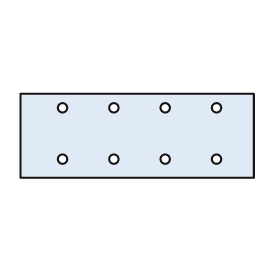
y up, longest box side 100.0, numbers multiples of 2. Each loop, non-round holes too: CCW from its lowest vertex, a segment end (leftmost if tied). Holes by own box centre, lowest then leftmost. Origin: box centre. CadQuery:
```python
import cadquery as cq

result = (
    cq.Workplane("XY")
    .moveTo(-50.0, -18.0)
    .lineTo(50.0, -18.0)
    .lineTo(50.0, 18.0)
    .lineTo(-50.0, 18.0)
    .close()
    .moveTo(-32.0, -10.0)
    .circle(2.0)
    .moveTo(-10.0, -10.0)
    .circle(2.0)
    .moveTo(12.0, -10.0)
    .circle(2.0)
    .moveTo(34.0, -10.0)
    .circle(2.0)
    .moveTo(-32.0, 12.0)
    .circle(2.0)
    .moveTo(-10.0, 12.0)
    .circle(2.0)
    .moveTo(12.0, 12.0)
    .circle(2.0)
    .moveTo(34.0, 12.0)
    .circle(2.0)
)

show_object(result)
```